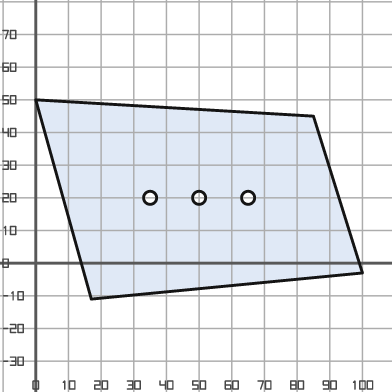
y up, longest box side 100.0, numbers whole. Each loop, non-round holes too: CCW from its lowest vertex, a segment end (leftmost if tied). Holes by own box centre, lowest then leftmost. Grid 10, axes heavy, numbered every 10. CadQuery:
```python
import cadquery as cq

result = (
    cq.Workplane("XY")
    .moveTo(17.0, -11.0)
    .lineTo(100.0, -3.0)
    .lineTo(85.0, 45.0)
    .lineTo(0.0, 50.0)
    .close()
    .moveTo(35.0, 20.0)
    .circle(2.0)
    .moveTo(50.0, 20.0)
    .circle(2.0)
    .moveTo(65.0, 20.0)
    .circle(2.0)
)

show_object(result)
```